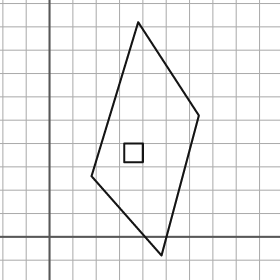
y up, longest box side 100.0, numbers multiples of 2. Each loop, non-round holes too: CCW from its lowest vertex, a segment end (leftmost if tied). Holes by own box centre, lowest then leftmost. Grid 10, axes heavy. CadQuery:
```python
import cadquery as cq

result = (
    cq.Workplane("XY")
    .moveTo(48.0, -8.0)
    .lineTo(64.0, 52.0)
    .lineTo(38.0, 92.0)
    .lineTo(18.0, 26.0)
    .close()
    .moveTo(32.0, 32.0)
    .lineTo(40.0, 32.0)
    .lineTo(40.0, 40.0)
    .lineTo(32.0, 40.0)
    .close()
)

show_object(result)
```